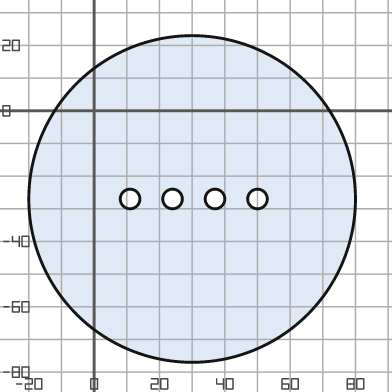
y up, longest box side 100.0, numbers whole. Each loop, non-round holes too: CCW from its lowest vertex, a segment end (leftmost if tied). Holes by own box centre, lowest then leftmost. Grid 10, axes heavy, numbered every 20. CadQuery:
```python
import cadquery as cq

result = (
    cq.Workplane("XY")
    .moveTo(30.0, -27.0)
    .circle(50.0)
    .moveTo(11.0, -27.0)
    .circle(3.0)
    .moveTo(24.0, -27.0)
    .circle(3.0)
    .moveTo(37.0, -27.0)
    .circle(3.0)
    .moveTo(50.0, -27.0)
    .circle(3.0)
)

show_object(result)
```